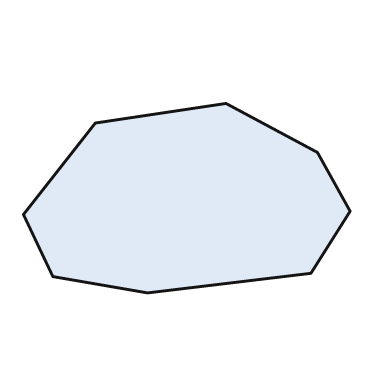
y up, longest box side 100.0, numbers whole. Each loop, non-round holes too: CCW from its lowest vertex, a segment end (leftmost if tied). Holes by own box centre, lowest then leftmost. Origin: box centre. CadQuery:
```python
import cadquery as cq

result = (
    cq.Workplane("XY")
    .moveTo(-12.0, -29.0)
    .lineTo(38.0, -23.0)
    .lineTo(50.0, -4.0)
    .lineTo(40.0, 14.0)
    .lineTo(12.0, 29.0)
    .lineTo(-28.0, 23.0)
    .lineTo(-50.0, -5.0)
    .lineTo(-41.0, -24.0)
    .close()
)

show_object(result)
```